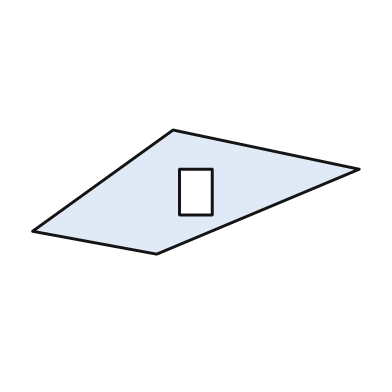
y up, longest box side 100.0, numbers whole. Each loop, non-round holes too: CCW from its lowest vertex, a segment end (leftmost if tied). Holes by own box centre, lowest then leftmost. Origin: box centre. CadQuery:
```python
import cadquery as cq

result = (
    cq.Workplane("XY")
    .moveTo(-12.0, -19.0)
    .lineTo(50.0, 7.0)
    .lineTo(-7.0, 19.0)
    .lineTo(-50.0, -12.0)
    .close()
    .moveTo(-5.0, -7.0)
    .lineTo(5.0, -7.0)
    .lineTo(5.0, 7.0)
    .lineTo(-5.0, 7.0)
    .close()
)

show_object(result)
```